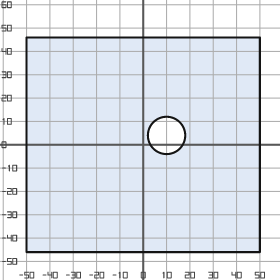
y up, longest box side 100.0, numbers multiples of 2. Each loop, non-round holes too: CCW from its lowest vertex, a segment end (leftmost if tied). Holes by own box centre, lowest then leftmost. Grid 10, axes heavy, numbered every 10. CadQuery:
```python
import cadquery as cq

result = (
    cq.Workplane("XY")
    .moveTo(-50.0, -46.0)
    .lineTo(50.0, -46.0)
    .lineTo(50.0, 46.0)
    .lineTo(-50.0, 46.0)
    .close()
    .moveTo(10.0, 4.0)
    .circle(8.0)
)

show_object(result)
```